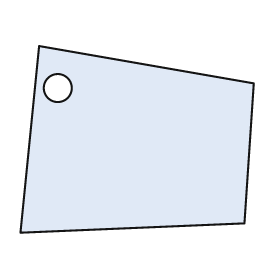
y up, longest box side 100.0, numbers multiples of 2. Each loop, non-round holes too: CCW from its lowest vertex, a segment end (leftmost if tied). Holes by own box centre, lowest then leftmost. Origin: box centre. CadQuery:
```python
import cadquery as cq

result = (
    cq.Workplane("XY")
    .moveTo(-50.0, -40.0)
    .lineTo(46.0, -36.0)
    .lineTo(50.0, 24.0)
    .lineTo(-42.0, 40.0)
    .close()
    .moveTo(-34.0, 22.0)
    .circle(6.0)
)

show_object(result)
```